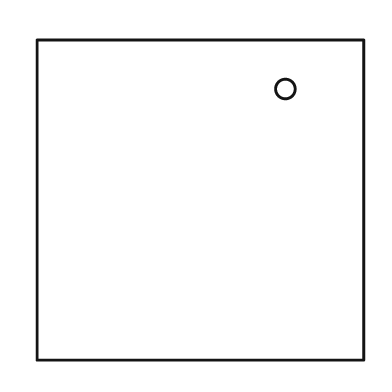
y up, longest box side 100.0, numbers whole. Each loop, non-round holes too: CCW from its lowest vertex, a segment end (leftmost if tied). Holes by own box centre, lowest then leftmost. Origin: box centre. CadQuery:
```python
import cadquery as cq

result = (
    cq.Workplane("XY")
    .moveTo(-50.0, -49.0)
    .lineTo(50.0, -49.0)
    .lineTo(50.0, 49.0)
    .lineTo(-50.0, 49.0)
    .close()
    .moveTo(26.0, 34.0)
    .circle(3.0)
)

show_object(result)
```